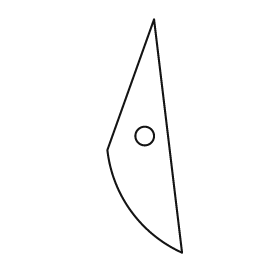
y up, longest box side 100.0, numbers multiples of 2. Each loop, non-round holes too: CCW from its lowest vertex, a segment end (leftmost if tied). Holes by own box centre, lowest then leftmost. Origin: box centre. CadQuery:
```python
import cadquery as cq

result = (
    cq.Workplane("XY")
    .moveTo(16.0, -50.0)
    .lineTo(4.0, 50.0)
    .lineTo(-16.0, -6.0)
    .threePointArc((-6.0, -32.0), (16.0, -50.0))
    .close()
    .moveTo(0.0, 0.0)
    .circle(4.0)
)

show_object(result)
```